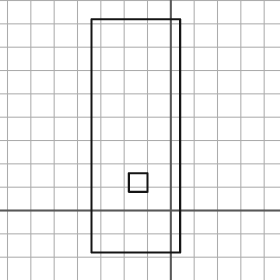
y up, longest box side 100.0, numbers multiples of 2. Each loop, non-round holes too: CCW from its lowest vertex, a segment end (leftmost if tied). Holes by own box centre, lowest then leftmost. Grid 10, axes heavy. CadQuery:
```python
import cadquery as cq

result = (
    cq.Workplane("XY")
    .moveTo(-34.0, -18.0)
    .lineTo(4.0, -18.0)
    .lineTo(4.0, 82.0)
    .lineTo(-34.0, 82.0)
    .close()
    .moveTo(-18.0, 8.0)
    .lineTo(-10.0, 8.0)
    .lineTo(-10.0, 16.0)
    .lineTo(-18.0, 16.0)
    .close()
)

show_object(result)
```